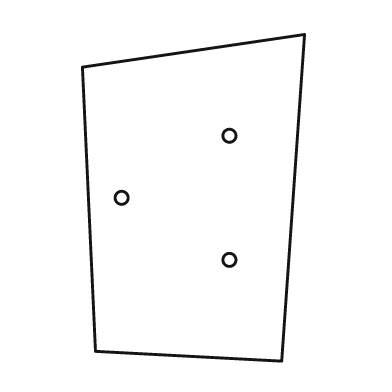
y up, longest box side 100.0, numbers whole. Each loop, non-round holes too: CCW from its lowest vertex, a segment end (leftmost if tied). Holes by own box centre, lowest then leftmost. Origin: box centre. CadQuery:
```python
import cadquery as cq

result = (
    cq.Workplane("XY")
    .moveTo(27.0, -50.0)
    .lineTo(34.0, 50.0)
    .lineTo(-34.0, 40.0)
    .lineTo(-30.0, -47.0)
    .close()
    .moveTo(11.0, -19.0)
    .circle(2.0)
    .moveTo(-22.0, 0.0)
    .circle(2.0)
    .moveTo(11.0, 19.0)
    .circle(2.0)
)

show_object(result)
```